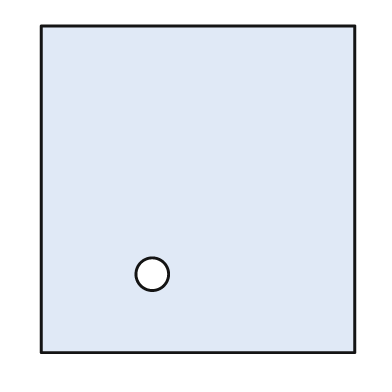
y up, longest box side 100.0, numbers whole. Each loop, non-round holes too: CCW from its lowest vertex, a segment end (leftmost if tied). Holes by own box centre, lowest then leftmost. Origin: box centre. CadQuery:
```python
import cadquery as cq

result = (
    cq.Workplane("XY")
    .moveTo(-48.0, -50.0)
    .lineTo(48.0, -50.0)
    .lineTo(48.0, 50.0)
    .lineTo(-48.0, 50.0)
    .close()
    .moveTo(-14.0, -26.0)
    .circle(5.0)
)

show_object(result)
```